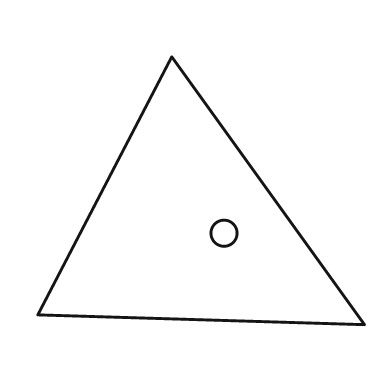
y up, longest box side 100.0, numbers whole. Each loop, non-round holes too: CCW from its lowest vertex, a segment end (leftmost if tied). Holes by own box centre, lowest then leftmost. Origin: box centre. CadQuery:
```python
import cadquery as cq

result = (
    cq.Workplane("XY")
    .moveTo(50.0, -41.0)
    .lineTo(-9.0, 41.0)
    .lineTo(-50.0, -38.0)
    .close()
    .moveTo(7.0, -13.0)
    .circle(4.0)
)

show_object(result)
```